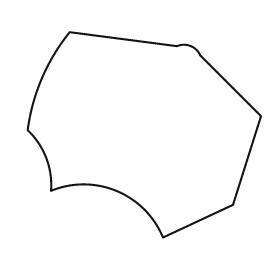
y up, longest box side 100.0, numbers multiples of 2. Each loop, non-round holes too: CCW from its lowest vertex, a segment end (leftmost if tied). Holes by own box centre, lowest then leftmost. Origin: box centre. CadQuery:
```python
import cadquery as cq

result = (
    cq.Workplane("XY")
    .moveTo(8.0, -44.0)
    .lineTo(38.0, -30.0)
    .lineTo(50.0, 8.0)
    .lineTo(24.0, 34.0)
    .threePointArc((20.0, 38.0), (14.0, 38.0))
    .lineTo(-32.0, 44.0)
    .threePointArc((-44.0, 24.0), (-50.0, 2.0))
    .threePointArc((-42.0, -10.0), (-40.0, -24.0))
    .threePointArc((-12.0, -24.0), (8.0, -44.0))
    .close()
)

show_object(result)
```